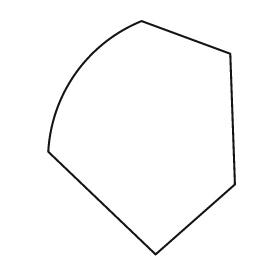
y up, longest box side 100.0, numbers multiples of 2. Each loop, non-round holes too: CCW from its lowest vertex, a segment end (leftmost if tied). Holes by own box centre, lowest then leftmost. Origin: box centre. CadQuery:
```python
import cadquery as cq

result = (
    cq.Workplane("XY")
    .moveTo(6.0, -50.0)
    .lineTo(40.0, -20.0)
    .lineTo(38.0, 36.0)
    .lineTo(0.0, 50.0)
    .threePointArc((-28.0, 28.0), (-40.0, -6.0))
    .close()
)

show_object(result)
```